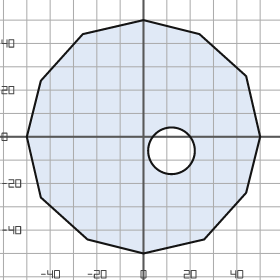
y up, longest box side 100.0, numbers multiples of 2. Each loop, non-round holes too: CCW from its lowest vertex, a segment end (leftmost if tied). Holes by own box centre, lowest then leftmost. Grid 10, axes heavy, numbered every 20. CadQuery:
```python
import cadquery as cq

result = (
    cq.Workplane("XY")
    .moveTo(0.0, -50.0)
    .lineTo(26.0, -44.0)
    .lineTo(44.0, -24.0)
    .lineTo(50.0, 0.0)
    .lineTo(44.0, 26.0)
    .lineTo(24.0, 44.0)
    .lineTo(0.0, 50.0)
    .lineTo(-26.0, 44.0)
    .lineTo(-44.0, 24.0)
    .lineTo(-50.0, 0.0)
    .lineTo(-44.0, -26.0)
    .lineTo(-24.0, -44.0)
    .close()
    .moveTo(12.0, -6.0)
    .circle(10.0)
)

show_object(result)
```